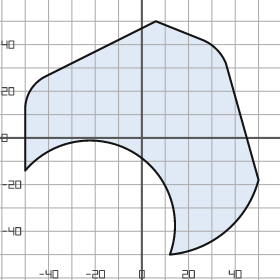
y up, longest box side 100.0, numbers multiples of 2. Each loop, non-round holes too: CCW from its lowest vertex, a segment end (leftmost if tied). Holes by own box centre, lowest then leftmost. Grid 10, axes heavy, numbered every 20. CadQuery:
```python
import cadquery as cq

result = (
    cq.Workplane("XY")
    .moveTo(12.0, -50.0)
    .threePointArc((36.0, -40.0), (50.0, -18.0))
    .lineTo(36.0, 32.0)
    .threePointArc((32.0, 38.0), (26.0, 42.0))
    .lineTo(6.0, 50.0)
    .lineTo(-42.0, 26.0)
    .threePointArc((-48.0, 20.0), (-50.0, 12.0))
    .lineTo(-50.0, -14.0)
    .threePointArc((-4.0, -6.0), (12.0, -50.0))
    .close()
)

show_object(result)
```